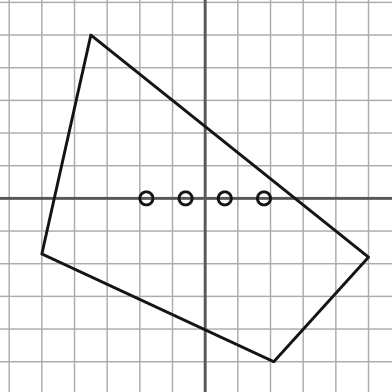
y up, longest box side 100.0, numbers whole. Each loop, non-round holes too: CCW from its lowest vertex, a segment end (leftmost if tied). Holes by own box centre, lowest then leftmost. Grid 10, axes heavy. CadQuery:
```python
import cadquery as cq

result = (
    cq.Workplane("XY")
    .moveTo(21.0, -50.0)
    .lineTo(50.0, -18.0)
    .lineTo(-35.0, 50.0)
    .lineTo(-50.0, -17.0)
    .close()
    .moveTo(-18.0, 0.0)
    .circle(2.0)
    .moveTo(-6.0, 0.0)
    .circle(2.0)
    .moveTo(6.0, 0.0)
    .circle(2.0)
    .moveTo(18.0, 0.0)
    .circle(2.0)
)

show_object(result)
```